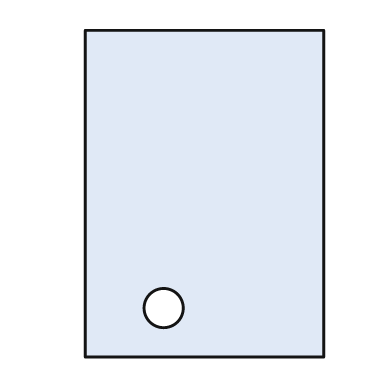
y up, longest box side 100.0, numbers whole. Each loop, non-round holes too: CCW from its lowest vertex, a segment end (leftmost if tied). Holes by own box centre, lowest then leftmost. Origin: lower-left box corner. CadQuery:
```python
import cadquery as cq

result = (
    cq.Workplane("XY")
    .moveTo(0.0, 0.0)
    .lineTo(73.0, 0.0)
    .lineTo(73.0, 100.0)
    .lineTo(0.0, 100.0)
    .close()
    .moveTo(24.0, 15.0)
    .circle(6.0)
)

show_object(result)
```